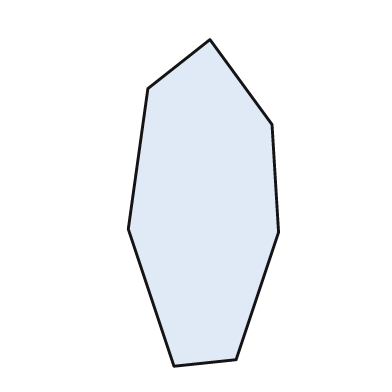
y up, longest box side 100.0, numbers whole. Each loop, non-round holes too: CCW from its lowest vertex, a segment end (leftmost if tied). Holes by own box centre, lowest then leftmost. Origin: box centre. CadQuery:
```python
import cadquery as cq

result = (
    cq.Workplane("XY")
    .moveTo(-9.0, -50.0)
    .lineTo(10.0, -48.0)
    .lineTo(23.0, -9.0)
    .lineTo(21.0, 24.0)
    .lineTo(2.0, 50.0)
    .lineTo(-17.0, 35.0)
    .lineTo(-23.0, -8.0)
    .close()
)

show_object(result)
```